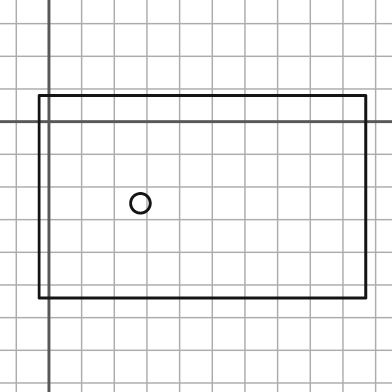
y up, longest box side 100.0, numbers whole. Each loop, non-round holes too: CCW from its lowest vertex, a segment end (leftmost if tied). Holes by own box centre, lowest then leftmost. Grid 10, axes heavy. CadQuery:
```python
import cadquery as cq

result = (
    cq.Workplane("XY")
    .moveTo(-3.0, -54.0)
    .lineTo(97.0, -54.0)
    .lineTo(97.0, 8.0)
    .lineTo(-3.0, 8.0)
    .close()
    .moveTo(28.0, -25.0)
    .circle(3.0)
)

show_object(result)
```